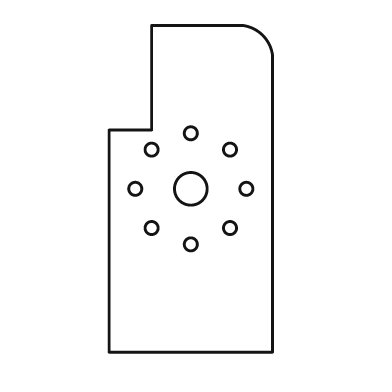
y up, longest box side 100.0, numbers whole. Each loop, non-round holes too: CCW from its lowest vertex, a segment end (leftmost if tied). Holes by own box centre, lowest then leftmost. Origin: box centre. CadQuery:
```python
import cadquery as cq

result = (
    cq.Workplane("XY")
    .moveTo(-25.0, -50.0)
    .lineTo(25.0, -50.0)
    .lineTo(25.0, 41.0)
    .threePointArc((22.0, 47.0), (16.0, 50.0))
    .lineTo(-12.0, 50.0)
    .lineTo(-12.0, 18.0)
    .lineTo(-25.0, 18.0)
    .close()
    .moveTo(0.0, -17.0)
    .circle(2.0)
    .moveTo(-12.0, -12.0)
    .circle(2.0)
    .moveTo(12.0, -12.0)
    .circle(2.0)
    .moveTo(-17.0, 0.0)
    .circle(2.0)
    .moveTo(0.0, 0.0)
    .circle(5.0)
    .moveTo(17.0, 0.0)
    .circle(2.0)
    .moveTo(-12.0, 12.0)
    .circle(2.0)
    .moveTo(12.0, 12.0)
    .circle(2.0)
    .moveTo(0.0, 17.0)
    .circle(2.0)
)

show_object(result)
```